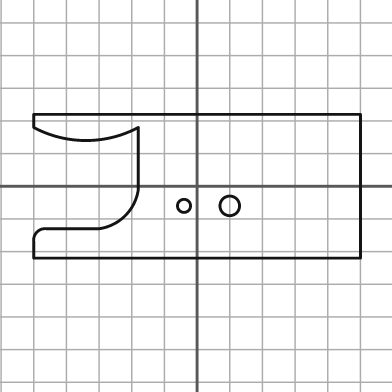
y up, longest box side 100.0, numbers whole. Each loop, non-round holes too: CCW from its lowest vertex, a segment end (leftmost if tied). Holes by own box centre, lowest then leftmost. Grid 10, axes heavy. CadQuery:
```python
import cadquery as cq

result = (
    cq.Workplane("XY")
    .moveTo(-50.0, -22.0)
    .lineTo(50.0, -22.0)
    .lineTo(50.0, 22.0)
    .lineTo(-50.0, 22.0)
    .lineTo(-50.0, 18.0)
    .threePointArc((-34.0, 14.0), (-18.0, 18.0))
    .lineTo(-18.0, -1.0)
    .threePointArc((-22.0, -9.0), (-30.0, -13.0))
    .lineTo(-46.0, -13.0)
    .threePointArc((-49.0, -14.0), (-50.0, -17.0))
    .close()
    .moveTo(-4.0, -6.0)
    .circle(2.0)
    .moveTo(10.0, -6.0)
    .circle(3.0)
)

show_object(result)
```